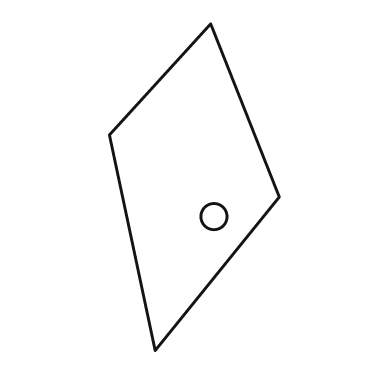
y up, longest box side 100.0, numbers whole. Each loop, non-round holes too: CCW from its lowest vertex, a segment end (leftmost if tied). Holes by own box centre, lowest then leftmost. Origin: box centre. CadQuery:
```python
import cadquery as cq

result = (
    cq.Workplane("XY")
    .moveTo(-12.0, -50.0)
    .lineTo(26.0, -3.0)
    .lineTo(5.0, 50.0)
    .lineTo(-26.0, 16.0)
    .close()
    .moveTo(6.0, -9.0)
    .circle(4.0)
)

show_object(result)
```